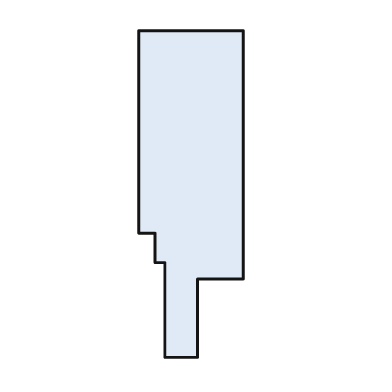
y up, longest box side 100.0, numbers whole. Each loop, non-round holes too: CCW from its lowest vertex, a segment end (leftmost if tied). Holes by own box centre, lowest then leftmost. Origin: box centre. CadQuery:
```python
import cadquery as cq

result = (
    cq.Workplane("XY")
    .moveTo(-8.0, -50.0)
    .lineTo(2.0, -50.0)
    .lineTo(2.0, -26.0)
    .lineTo(16.0, -26.0)
    .lineTo(16.0, 50.0)
    .lineTo(-16.0, 50.0)
    .lineTo(-16.0, -12.0)
    .lineTo(-11.0, -12.0)
    .lineTo(-11.0, -21.0)
    .lineTo(-8.0, -21.0)
    .close()
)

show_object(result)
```